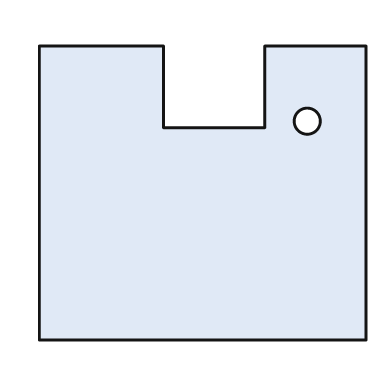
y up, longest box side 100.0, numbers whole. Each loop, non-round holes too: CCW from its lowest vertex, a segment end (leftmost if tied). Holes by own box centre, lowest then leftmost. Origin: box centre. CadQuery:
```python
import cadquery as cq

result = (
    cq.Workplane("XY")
    .moveTo(-50.0, -45.0)
    .lineTo(50.0, -45.0)
    .lineTo(50.0, 45.0)
    .lineTo(19.0, 45.0)
    .lineTo(19.0, 20.0)
    .lineTo(-12.0, 20.0)
    .lineTo(-12.0, 45.0)
    .lineTo(-50.0, 45.0)
    .close()
    .moveTo(32.0, 22.0)
    .circle(4.0)
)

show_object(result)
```